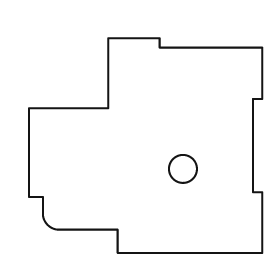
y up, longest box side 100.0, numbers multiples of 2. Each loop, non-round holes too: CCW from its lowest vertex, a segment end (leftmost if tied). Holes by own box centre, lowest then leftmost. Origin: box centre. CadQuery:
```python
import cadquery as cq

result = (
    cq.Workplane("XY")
    .moveTo(-12.0, -46.0)
    .lineTo(50.0, -46.0)
    .lineTo(50.0, -20.0)
    .lineTo(46.0, -20.0)
    .lineTo(46.0, 20.0)
    .lineTo(50.0, 20.0)
    .lineTo(50.0, 42.0)
    .lineTo(6.0, 42.0)
    .lineTo(6.0, 46.0)
    .lineTo(-16.0, 46.0)
    .lineTo(-16.0, 16.0)
    .lineTo(-50.0, 16.0)
    .lineTo(-50.0, -22.0)
    .lineTo(-44.0, -22.0)
    .lineTo(-44.0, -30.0)
    .threePointArc((-42.0, -34.0), (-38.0, -36.0))
    .lineTo(-12.0, -36.0)
    .close()
    .moveTo(16.0, -10.0)
    .circle(6.0)
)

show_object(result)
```